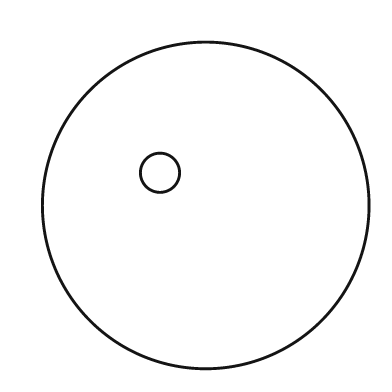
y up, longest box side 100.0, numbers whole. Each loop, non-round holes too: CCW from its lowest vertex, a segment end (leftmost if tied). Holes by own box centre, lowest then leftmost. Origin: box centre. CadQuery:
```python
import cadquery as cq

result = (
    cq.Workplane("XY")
    .moveTo(0.0, 0.0)
    .circle(50.0)
    .moveTo(-14.0, 10.0)
    .circle(6.0)
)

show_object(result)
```